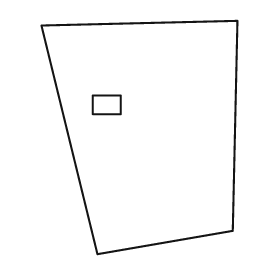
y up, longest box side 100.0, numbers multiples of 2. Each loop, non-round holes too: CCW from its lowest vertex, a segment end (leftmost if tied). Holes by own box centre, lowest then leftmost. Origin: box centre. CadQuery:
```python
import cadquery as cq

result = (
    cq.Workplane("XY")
    .moveTo(-18.0, -50.0)
    .lineTo(40.0, -40.0)
    .lineTo(42.0, 50.0)
    .lineTo(-42.0, 48.0)
    .close()
    .moveTo(-20.0, 10.0)
    .lineTo(-8.0, 10.0)
    .lineTo(-8.0, 18.0)
    .lineTo(-20.0, 18.0)
    .close()
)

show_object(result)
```